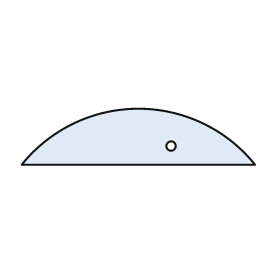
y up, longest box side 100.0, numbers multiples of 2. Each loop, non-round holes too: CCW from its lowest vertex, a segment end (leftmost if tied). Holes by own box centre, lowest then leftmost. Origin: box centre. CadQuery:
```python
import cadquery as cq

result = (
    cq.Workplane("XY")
    .moveTo(-50.0, -12.0)
    .lineTo(50.0, -12.0)
    .threePointArc((0.0, 12.0), (-50.0, -12.0))
    .close()
    .moveTo(14.0, -4.0)
    .circle(2.0)
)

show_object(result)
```